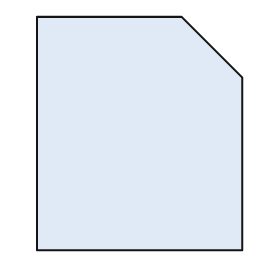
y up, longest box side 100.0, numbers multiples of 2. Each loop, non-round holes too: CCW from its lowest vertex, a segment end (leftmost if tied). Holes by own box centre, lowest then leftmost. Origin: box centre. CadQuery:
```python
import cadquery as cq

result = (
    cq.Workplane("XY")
    .moveTo(-44.0, -50.0)
    .lineTo(44.0, -50.0)
    .lineTo(44.0, 24.0)
    .lineTo(18.0, 50.0)
    .lineTo(-44.0, 50.0)
    .close()
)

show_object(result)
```